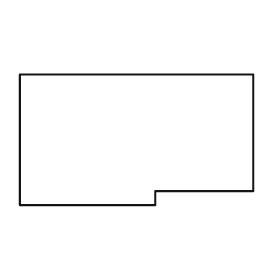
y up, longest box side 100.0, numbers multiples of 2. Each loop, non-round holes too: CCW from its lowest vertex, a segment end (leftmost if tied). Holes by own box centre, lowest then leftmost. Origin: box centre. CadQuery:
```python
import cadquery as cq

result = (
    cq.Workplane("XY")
    .moveTo(-50.0, -28.0)
    .lineTo(8.0, -28.0)
    .lineTo(8.0, -22.0)
    .lineTo(50.0, -22.0)
    .lineTo(50.0, 28.0)
    .lineTo(-50.0, 28.0)
    .close()
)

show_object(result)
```